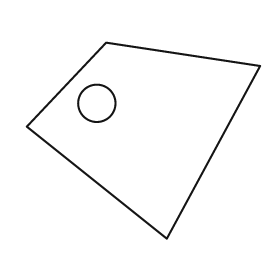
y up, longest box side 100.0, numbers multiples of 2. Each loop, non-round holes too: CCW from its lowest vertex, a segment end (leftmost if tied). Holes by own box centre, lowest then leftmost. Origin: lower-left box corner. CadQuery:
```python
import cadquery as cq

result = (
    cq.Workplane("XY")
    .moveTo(60.0, 0.0)
    .lineTo(100.0, 74.0)
    .lineTo(34.0, 84.0)
    .lineTo(0.0, 48.0)
    .close()
    .moveTo(30.0, 58.0)
    .circle(8.0)
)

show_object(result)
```